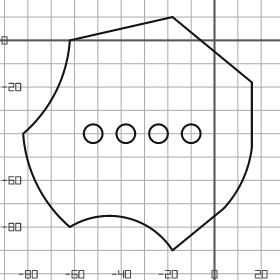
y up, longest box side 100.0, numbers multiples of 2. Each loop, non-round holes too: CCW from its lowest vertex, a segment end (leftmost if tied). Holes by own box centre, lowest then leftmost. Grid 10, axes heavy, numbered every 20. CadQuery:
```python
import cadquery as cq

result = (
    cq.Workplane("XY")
    .moveTo(-18.0, -90.0)
    .lineTo(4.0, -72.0)
    .threePointArc((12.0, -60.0), (16.0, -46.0))
    .lineTo(16.0, -18.0)
    .lineTo(-18.0, 10.0)
    .lineTo(-62.0, 0.0)
    .threePointArc((-68.0, -22.0), (-82.0, -40.0))
    .threePointArc((-76.0, -62.0), (-62.0, -80.0))
    .threePointArc((-38.0, -76.0), (-18.0, -90.0))
    .close()
    .moveTo(-52.0, -40.0)
    .circle(4.0)
    .moveTo(-38.0, -40.0)
    .circle(4.0)
    .moveTo(-24.0, -40.0)
    .circle(4.0)
    .moveTo(-10.0, -40.0)
    .circle(4.0)
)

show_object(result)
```